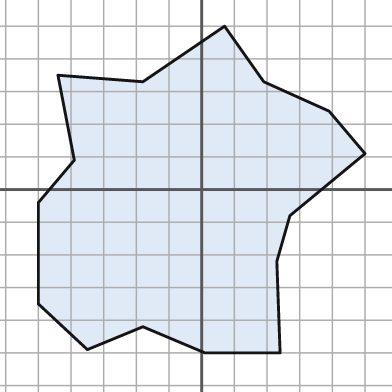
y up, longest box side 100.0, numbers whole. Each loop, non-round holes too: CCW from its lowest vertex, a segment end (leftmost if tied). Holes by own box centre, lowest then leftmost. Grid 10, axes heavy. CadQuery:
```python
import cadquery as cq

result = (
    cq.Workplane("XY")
    .moveTo(1.0, -50.0)
    .lineTo(24.0, -50.0)
    .lineTo(23.0, -22.0)
    .lineTo(27.0, -8.0)
    .lineTo(50.0, 11.0)
    .lineTo(39.0, 24.0)
    .lineTo(19.0, 33.0)
    .lineTo(7.0, 50.0)
    .lineTo(-18.0, 33.0)
    .lineTo(-44.0, 35.0)
    .lineTo(-39.0, 9.0)
    .lineTo(-50.0, -4.0)
    .lineTo(-50.0, -35.0)
    .lineTo(-35.0, -49.0)
    .lineTo(-18.0, -42.0)
    .close()
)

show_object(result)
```